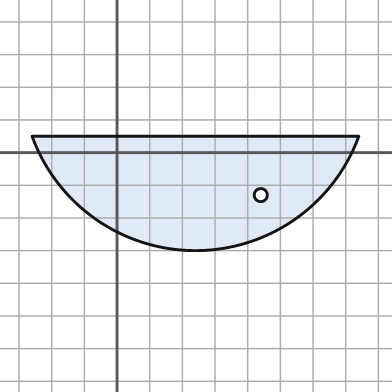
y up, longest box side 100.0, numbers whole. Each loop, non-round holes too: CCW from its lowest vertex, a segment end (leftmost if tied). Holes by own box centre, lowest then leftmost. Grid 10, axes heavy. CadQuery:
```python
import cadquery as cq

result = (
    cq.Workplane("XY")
    .moveTo(-26.0, 5.0)
    .threePointArc((24.0, -30.0), (74.0, 5.0))
    .close()
    .moveTo(44.0, -13.0)
    .circle(2.0)
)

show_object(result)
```